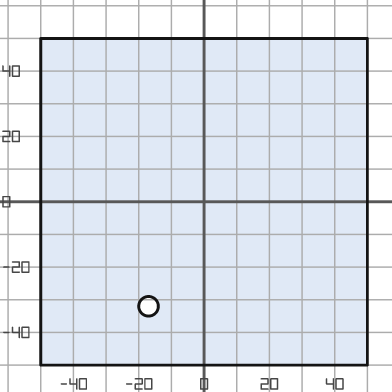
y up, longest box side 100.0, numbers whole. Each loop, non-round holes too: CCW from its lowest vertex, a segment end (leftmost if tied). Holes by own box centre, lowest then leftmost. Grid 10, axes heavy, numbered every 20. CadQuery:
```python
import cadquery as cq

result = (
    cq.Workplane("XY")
    .moveTo(-50.0, -50.0)
    .lineTo(50.0, -50.0)
    .lineTo(50.0, 50.0)
    .lineTo(-50.0, 50.0)
    .close()
    .moveTo(-17.0, -32.0)
    .circle(3.0)
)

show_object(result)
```